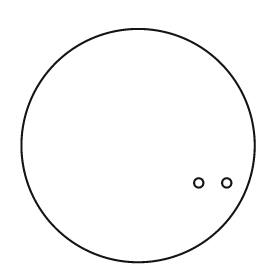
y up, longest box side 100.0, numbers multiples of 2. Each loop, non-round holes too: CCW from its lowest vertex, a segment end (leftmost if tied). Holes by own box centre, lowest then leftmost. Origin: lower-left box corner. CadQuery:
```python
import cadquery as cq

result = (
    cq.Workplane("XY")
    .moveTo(50.0, 50.0)
    .circle(50.0)
    .moveTo(76.0, 34.0)
    .circle(2.0)
    .moveTo(88.0, 34.0)
    .circle(2.0)
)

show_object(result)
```